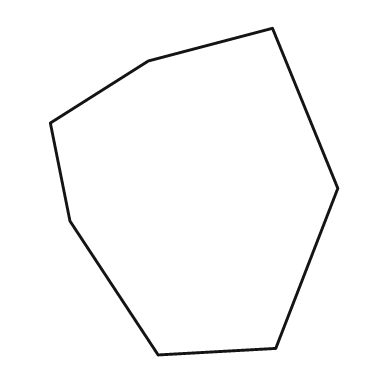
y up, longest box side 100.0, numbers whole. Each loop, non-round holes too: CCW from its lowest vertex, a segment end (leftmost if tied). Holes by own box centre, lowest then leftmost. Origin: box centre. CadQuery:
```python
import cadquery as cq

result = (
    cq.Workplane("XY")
    .moveTo(-11.0, -50.0)
    .lineTo(25.0, -48.0)
    .lineTo(44.0, 1.0)
    .lineTo(24.0, 50.0)
    .lineTo(-14.0, 40.0)
    .lineTo(-44.0, 21.0)
    .lineTo(-38.0, -9.0)
    .close()
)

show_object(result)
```